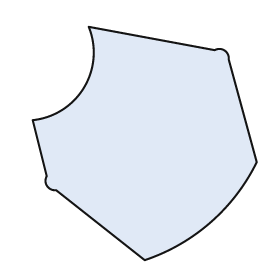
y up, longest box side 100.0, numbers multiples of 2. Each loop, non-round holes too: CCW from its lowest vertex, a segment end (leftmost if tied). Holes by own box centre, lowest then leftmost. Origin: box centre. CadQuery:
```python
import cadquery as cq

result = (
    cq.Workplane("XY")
    .moveTo(0.0, -50.0)
    .threePointArc((28.0, -34.0), (48.0, -8.0))
    .lineTo(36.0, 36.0)
    .threePointArc((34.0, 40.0), (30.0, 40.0))
    .lineTo(-24.0, 50.0)
    .threePointArc((-26.0, 24.0), (-48.0, 10.0))
    .lineTo(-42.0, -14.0)
    .threePointArc((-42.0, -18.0), (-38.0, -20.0))
    .close()
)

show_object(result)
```